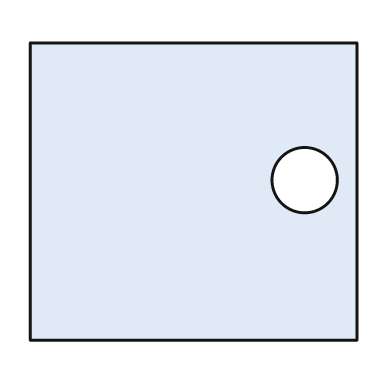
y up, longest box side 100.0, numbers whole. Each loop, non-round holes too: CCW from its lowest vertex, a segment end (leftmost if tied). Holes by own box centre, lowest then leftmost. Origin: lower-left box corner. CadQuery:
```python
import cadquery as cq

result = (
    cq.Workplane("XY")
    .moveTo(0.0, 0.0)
    .lineTo(100.0, 0.0)
    .lineTo(100.0, 91.0)
    .lineTo(0.0, 91.0)
    .close()
    .moveTo(84.0, 49.0)
    .circle(10.0)
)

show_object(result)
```